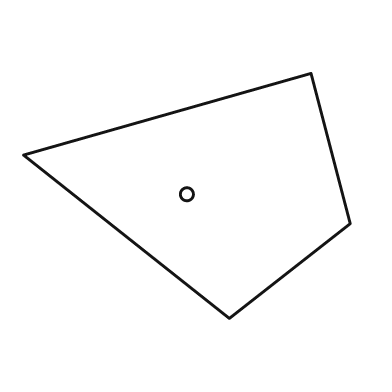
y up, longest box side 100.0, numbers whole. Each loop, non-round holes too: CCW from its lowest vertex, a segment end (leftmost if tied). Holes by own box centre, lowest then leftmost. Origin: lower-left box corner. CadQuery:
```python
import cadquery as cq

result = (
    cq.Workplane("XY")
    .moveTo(63.0, 0.0)
    .lineTo(100.0, 29.0)
    .lineTo(88.0, 75.0)
    .lineTo(0.0, 50.0)
    .close()
    .moveTo(50.0, 38.0)
    .circle(2.0)
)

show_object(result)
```